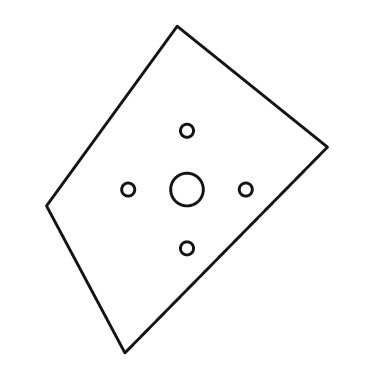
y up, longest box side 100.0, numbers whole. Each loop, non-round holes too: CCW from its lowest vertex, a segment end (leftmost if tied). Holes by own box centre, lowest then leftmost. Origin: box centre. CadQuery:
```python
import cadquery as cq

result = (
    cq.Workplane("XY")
    .moveTo(-19.0, -50.0)
    .lineTo(43.0, 13.0)
    .lineTo(-3.0, 50.0)
    .lineTo(-43.0, -5.0)
    .close()
    .moveTo(0.0, -18.0)
    .circle(2.0)
    .moveTo(-18.0, 0.0)
    .circle(2.0)
    .moveTo(0.0, 0.0)
    .circle(5.0)
    .moveTo(18.0, 0.0)
    .circle(2.0)
    .moveTo(0.0, 18.0)
    .circle(2.0)
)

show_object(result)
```